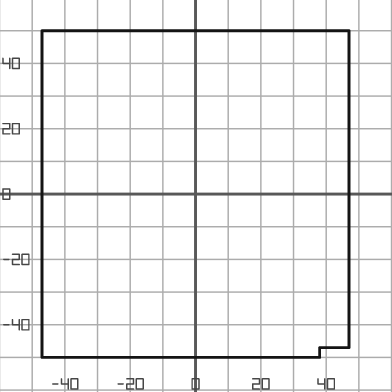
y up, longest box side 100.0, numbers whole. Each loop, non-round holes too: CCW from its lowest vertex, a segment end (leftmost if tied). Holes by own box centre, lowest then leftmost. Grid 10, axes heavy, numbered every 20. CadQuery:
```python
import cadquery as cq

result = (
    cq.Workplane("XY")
    .moveTo(-47.0, -50.0)
    .lineTo(38.0, -50.0)
    .lineTo(38.0, -47.0)
    .lineTo(47.0, -47.0)
    .lineTo(47.0, 50.0)
    .lineTo(-47.0, 50.0)
    .close()
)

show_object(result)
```